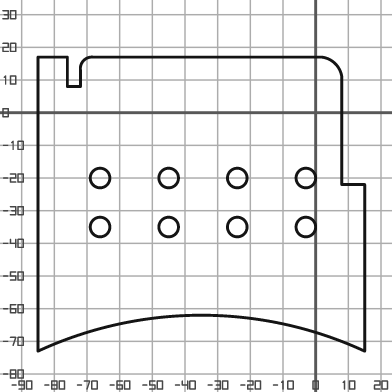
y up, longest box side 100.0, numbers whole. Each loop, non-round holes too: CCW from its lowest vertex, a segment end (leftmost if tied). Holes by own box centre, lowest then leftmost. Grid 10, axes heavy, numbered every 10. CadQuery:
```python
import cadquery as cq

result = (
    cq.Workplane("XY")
    .moveTo(-85.0, -73.0)
    .threePointArc((-35.0, -62.0), (15.0, -73.0))
    .lineTo(15.0, -22.0)
    .lineTo(8.0, -22.0)
    .lineTo(8.0, 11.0)
    .threePointArc((6.0, 15.0), (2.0, 17.0))
    .lineTo(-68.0, 17.0)
    .threePointArc((-71.0, 16.0), (-72.0, 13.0))
    .lineTo(-72.0, 8.0)
    .lineTo(-76.0, 8.0)
    .lineTo(-76.0, 17.0)
    .lineTo(-85.0, 17.0)
    .close()
    .moveTo(-66.0, -35.0)
    .circle(3.0)
    .moveTo(-45.0, -35.0)
    .circle(3.0)
    .moveTo(-24.0, -35.0)
    .circle(3.0)
    .moveTo(-3.0, -35.0)
    .circle(3.0)
    .moveTo(-66.0, -20.0)
    .circle(3.0)
    .moveTo(-45.0, -20.0)
    .circle(3.0)
    .moveTo(-24.0, -20.0)
    .circle(3.0)
    .moveTo(-3.0, -20.0)
    .circle(3.0)
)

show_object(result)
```